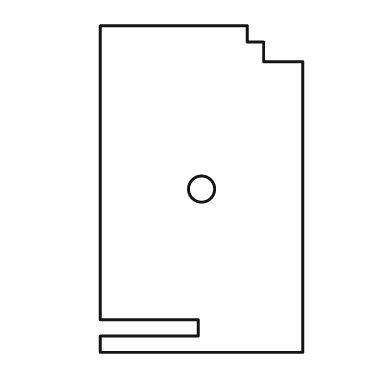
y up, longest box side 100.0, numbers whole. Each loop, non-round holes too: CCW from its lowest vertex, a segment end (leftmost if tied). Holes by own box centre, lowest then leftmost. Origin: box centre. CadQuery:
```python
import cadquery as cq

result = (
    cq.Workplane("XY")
    .moveTo(-31.0, -50.0)
    .lineTo(31.0, -50.0)
    .lineTo(31.0, 39.0)
    .lineTo(19.0, 39.0)
    .lineTo(19.0, 45.0)
    .lineTo(14.0, 45.0)
    .lineTo(14.0, 50.0)
    .lineTo(-31.0, 50.0)
    .lineTo(-31.0, -40.0)
    .lineTo(-1.0, -40.0)
    .lineTo(-1.0, -45.0)
    .lineTo(-31.0, -45.0)
    .close()
    .moveTo(0.0, 0.0)
    .circle(4.0)
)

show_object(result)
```